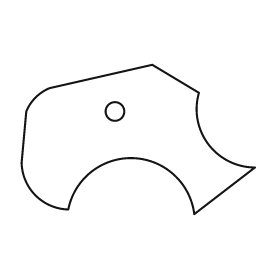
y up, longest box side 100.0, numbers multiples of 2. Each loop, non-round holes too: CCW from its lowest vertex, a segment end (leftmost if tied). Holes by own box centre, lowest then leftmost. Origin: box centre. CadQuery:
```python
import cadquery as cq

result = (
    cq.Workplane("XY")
    .moveTo(24.0, -32.0)
    .lineTo(50.0, -12.0)
    .threePointArc((30.0, -2.0), (26.0, 20.0))
    .lineTo(6.0, 32.0)
    .lineTo(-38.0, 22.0)
    .threePointArc((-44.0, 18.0), (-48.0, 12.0))
    .lineTo(-50.0, -10.0)
    .threePointArc((-44.0, -24.0), (-30.0, -30.0))
    .threePointArc((-2.0, -8.0), (24.0, -32.0))
    .close()
    .moveTo(-10.0, 12.0)
    .circle(4.0)
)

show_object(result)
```